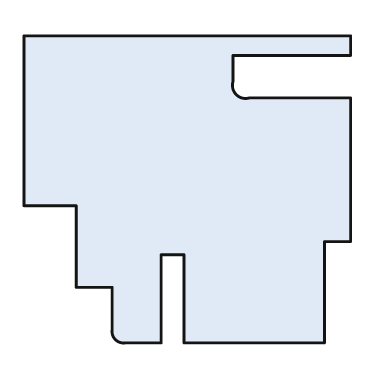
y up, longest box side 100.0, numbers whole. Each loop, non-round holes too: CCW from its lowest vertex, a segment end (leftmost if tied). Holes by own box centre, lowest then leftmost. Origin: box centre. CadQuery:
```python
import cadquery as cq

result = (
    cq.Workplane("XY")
    .moveTo(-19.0, -47.0)
    .lineTo(-8.0, -47.0)
    .lineTo(-8.0, -20.0)
    .lineTo(-1.0, -20.0)
    .lineTo(-1.0, -47.0)
    .lineTo(42.0, -47.0)
    .lineTo(42.0, -16.0)
    .lineTo(50.0, -16.0)
    .lineTo(50.0, 28.0)
    .lineTo(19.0, 28.0)
    .threePointArc((15.0, 29.0), (14.0, 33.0))
    .lineTo(14.0, 41.0)
    .lineTo(50.0, 41.0)
    .lineTo(50.0, 47.0)
    .lineTo(-50.0, 47.0)
    .lineTo(-50.0, -5.0)
    .lineTo(-34.0, -5.0)
    .lineTo(-34.0, -30.0)
    .lineTo(-23.0, -30.0)
    .lineTo(-23.0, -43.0)
    .threePointArc((-22.0, -46.0), (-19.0, -47.0))
    .close()
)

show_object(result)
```